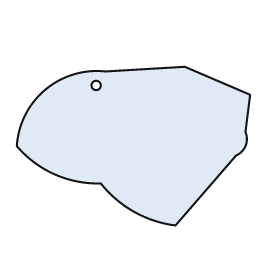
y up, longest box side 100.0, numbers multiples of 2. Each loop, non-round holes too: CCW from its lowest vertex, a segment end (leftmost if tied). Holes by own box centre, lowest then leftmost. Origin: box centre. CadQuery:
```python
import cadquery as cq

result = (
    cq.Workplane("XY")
    .moveTo(18.0, -34.0)
    .lineTo(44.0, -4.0)
    .threePointArc((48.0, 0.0), (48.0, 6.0))
    .lineTo(50.0, 22.0)
    .lineTo(22.0, 34.0)
    .lineTo(-12.0, 32.0)
    .threePointArc((-38.0, 24.0), (-50.0, 0.0))
    .threePointArc((-34.0, -12.0), (-14.0, -16.0))
    .threePointArc((0.0, -28.0), (18.0, -34.0))
    .close()
    .moveTo(-16.0, 26.0)
    .circle(2.0)
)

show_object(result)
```